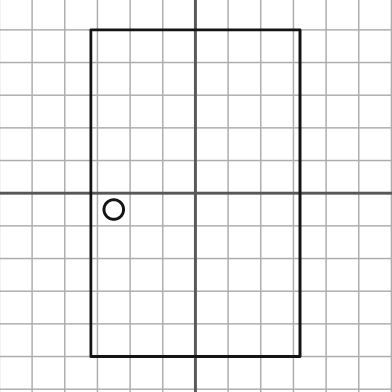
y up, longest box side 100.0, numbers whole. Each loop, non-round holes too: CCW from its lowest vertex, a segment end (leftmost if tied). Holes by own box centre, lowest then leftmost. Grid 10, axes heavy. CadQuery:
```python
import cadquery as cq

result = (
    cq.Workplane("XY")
    .moveTo(-32.0, -50.0)
    .lineTo(32.0, -50.0)
    .lineTo(32.0, 50.0)
    .lineTo(-32.0, 50.0)
    .close()
    .moveTo(-25.0, -5.0)
    .circle(3.0)
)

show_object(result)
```